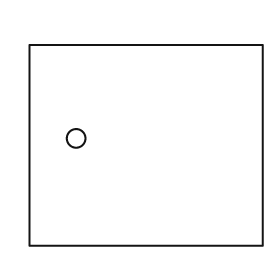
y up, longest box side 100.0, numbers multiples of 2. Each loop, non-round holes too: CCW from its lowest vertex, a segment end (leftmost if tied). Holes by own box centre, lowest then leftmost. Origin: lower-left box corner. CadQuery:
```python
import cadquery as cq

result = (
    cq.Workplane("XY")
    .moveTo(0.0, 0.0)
    .lineTo(100.0, 0.0)
    .lineTo(100.0, 86.0)
    .lineTo(0.0, 86.0)
    .close()
    .moveTo(20.0, 46.0)
    .circle(4.0)
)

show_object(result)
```